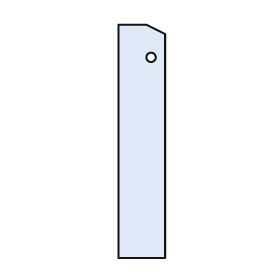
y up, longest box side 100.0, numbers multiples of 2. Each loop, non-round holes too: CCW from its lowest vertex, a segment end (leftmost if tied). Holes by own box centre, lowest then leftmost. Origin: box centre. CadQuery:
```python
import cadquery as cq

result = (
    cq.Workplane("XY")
    .moveTo(-10.0, -50.0)
    .lineTo(10.0, -50.0)
    .lineTo(10.0, 46.0)
    .lineTo(2.0, 50.0)
    .lineTo(-10.0, 50.0)
    .close()
    .moveTo(4.0, 36.0)
    .circle(2.0)
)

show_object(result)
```